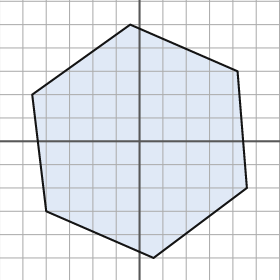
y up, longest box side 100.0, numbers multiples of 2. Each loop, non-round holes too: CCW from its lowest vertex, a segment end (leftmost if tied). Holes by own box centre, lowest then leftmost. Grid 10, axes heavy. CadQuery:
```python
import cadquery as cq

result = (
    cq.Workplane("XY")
    .moveTo(6.0, -50.0)
    .lineTo(46.0, -20.0)
    .lineTo(42.0, 30.0)
    .lineTo(-4.0, 50.0)
    .lineTo(-46.0, 20.0)
    .lineTo(-40.0, -30.0)
    .close()
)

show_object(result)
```